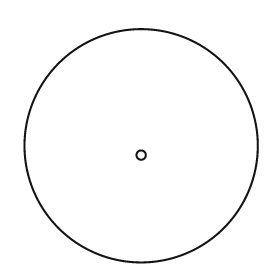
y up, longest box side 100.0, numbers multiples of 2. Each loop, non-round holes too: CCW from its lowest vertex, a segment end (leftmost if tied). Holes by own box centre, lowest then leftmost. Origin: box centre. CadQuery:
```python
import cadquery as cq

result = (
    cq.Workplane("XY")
    .moveTo(0.0, 0.0)
    .circle(50.0)
    .moveTo(0.0, -4.0)
    .circle(2.0)
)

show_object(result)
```